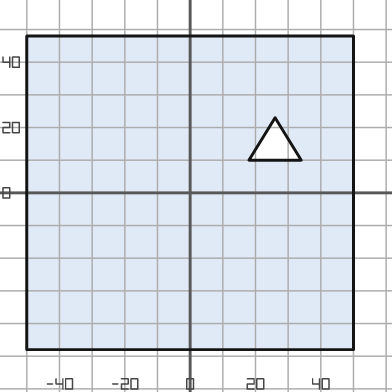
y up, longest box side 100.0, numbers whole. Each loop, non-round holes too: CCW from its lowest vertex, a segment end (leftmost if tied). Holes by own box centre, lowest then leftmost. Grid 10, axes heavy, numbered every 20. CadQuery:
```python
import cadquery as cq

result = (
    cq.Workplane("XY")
    .moveTo(-50.0, -48.0)
    .lineTo(50.0, -48.0)
    .lineTo(50.0, 48.0)
    .lineTo(-50.0, 48.0)
    .close()
    .moveTo(18.0, 10.0)
    .lineTo(34.0, 10.0)
    .lineTo(26.0, 23.0)
    .close()
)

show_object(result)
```